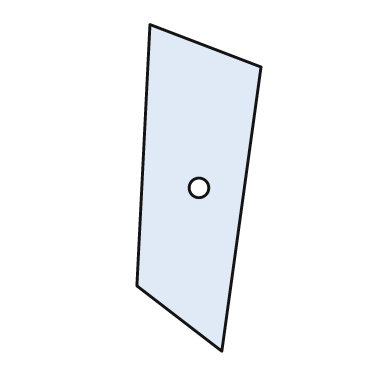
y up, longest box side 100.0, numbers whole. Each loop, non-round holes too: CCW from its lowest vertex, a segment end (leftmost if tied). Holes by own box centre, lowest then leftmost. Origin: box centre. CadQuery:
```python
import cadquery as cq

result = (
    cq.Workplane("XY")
    .moveTo(7.0, -50.0)
    .lineTo(19.0, 37.0)
    .lineTo(-15.0, 50.0)
    .lineTo(-19.0, -30.0)
    .close()
    .moveTo(0.0, 0.0)
    .circle(3.0)
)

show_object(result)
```